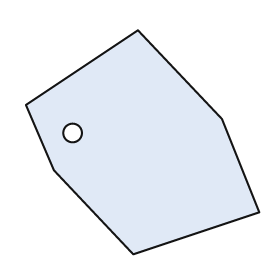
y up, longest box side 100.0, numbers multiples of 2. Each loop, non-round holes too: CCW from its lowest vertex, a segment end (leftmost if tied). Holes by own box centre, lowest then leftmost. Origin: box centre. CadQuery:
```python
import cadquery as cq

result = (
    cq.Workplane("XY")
    .moveTo(-4.0, -48.0)
    .lineTo(50.0, -30.0)
    .lineTo(34.0, 10.0)
    .lineTo(-2.0, 48.0)
    .lineTo(-50.0, 16.0)
    .lineTo(-38.0, -12.0)
    .close()
    .moveTo(-30.0, 4.0)
    .circle(4.0)
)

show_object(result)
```